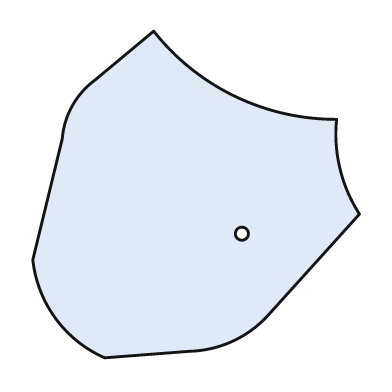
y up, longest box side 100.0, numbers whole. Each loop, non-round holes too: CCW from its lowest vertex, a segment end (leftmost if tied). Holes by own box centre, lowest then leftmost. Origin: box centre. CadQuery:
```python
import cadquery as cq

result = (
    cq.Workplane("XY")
    .moveTo(-28.0, -50.0)
    .lineTo(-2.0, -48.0)
    .threePointArc((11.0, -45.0), (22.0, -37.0))
    .lineTo(50.0, -6.0)
    .threePointArc((44.0, 8.0), (43.0, 23.0))
    .threePointArc((12.0, 30.0), (-13.0, 50.0))
    .lineTo(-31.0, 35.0)
    .threePointArc((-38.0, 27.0), (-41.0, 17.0))
    .lineTo(-50.0, -20.0)
    .threePointArc((-43.0, -38.0), (-28.0, -50.0))
    .close()
    .moveTo(14.0, -12.0)
    .circle(2.0)
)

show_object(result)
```